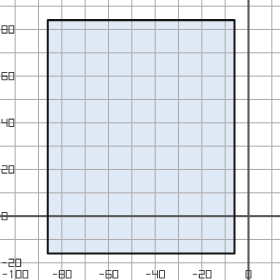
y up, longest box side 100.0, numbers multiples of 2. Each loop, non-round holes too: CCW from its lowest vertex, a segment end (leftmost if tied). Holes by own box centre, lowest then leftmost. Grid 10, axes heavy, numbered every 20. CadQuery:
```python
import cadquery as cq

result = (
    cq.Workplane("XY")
    .moveTo(-86.0, -16.0)
    .lineTo(-6.0, -16.0)
    .lineTo(-6.0, 84.0)
    .lineTo(-86.0, 84.0)
    .close()
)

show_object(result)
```